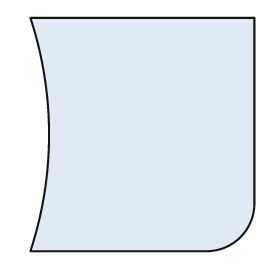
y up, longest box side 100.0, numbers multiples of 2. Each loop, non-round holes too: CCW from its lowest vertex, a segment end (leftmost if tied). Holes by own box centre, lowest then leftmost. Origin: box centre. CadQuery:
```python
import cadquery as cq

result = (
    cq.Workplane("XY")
    .moveTo(-48.0, -50.0)
    .lineTo(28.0, -50.0)
    .threePointArc((42.0, -44.0), (48.0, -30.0))
    .lineTo(48.0, 50.0)
    .lineTo(-48.0, 50.0)
    .threePointArc((-40.0, 0.0), (-48.0, -50.0))
    .close()
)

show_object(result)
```